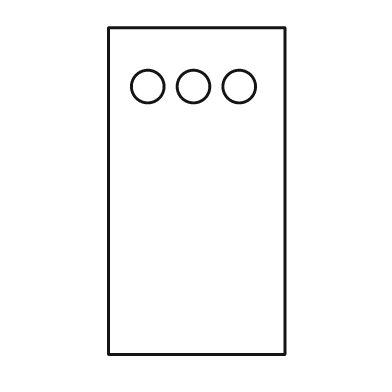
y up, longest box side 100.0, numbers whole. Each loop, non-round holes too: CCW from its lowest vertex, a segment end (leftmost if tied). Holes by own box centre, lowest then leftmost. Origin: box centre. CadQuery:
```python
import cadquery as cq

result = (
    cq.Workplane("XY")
    .moveTo(-27.0, -50.0)
    .lineTo(27.0, -50.0)
    .lineTo(27.0, 50.0)
    .lineTo(-27.0, 50.0)
    .close()
    .moveTo(-15.0, 32.0)
    .circle(5.0)
    .moveTo(-1.0, 32.0)
    .circle(5.0)
    .moveTo(13.0, 32.0)
    .circle(5.0)
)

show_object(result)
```